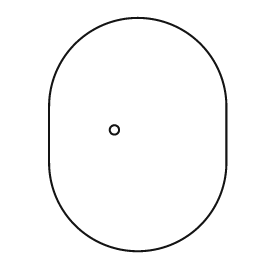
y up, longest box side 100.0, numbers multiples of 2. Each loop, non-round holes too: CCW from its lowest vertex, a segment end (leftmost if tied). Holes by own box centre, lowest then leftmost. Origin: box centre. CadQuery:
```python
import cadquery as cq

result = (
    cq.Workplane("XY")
    .moveTo(-38.0, -12.0)
    .threePointArc((0.0, -50.0), (38.0, -12.0))
    .lineTo(38.0, 12.0)
    .threePointArc((0.0, 50.0), (-38.0, 12.0))
    .close()
    .moveTo(-10.0, 2.0)
    .circle(2.0)
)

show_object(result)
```